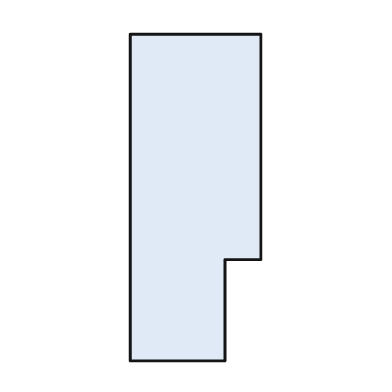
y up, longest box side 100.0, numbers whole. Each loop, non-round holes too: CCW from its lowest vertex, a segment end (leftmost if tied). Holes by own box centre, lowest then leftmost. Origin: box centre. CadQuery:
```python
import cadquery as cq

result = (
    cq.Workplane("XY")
    .moveTo(-20.0, -50.0)
    .lineTo(9.0, -50.0)
    .lineTo(9.0, -19.0)
    .lineTo(20.0, -19.0)
    .lineTo(20.0, 50.0)
    .lineTo(-20.0, 50.0)
    .close()
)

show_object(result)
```